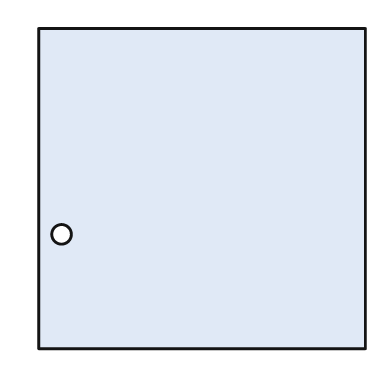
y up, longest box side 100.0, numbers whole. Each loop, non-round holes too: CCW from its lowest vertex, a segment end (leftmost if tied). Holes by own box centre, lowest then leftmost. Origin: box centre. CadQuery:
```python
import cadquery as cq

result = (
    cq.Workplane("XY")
    .moveTo(-50.0, -49.0)
    .lineTo(50.0, -49.0)
    .lineTo(50.0, 49.0)
    .lineTo(-50.0, 49.0)
    .close()
    .moveTo(-43.0, -14.0)
    .circle(3.0)
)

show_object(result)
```